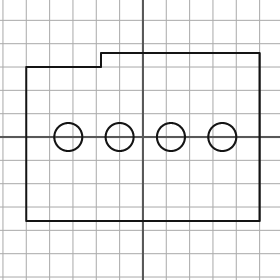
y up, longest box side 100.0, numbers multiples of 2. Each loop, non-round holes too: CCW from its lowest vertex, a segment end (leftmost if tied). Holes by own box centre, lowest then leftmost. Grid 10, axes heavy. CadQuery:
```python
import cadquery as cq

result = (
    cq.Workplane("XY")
    .moveTo(-50.0, -36.0)
    .lineTo(50.0, -36.0)
    .lineTo(50.0, 36.0)
    .lineTo(-18.0, 36.0)
    .lineTo(-18.0, 30.0)
    .lineTo(-50.0, 30.0)
    .close()
    .moveTo(-32.0, 0.0)
    .circle(6.0)
    .moveTo(-10.0, 0.0)
    .circle(6.0)
    .moveTo(12.0, 0.0)
    .circle(6.0)
    .moveTo(34.0, 0.0)
    .circle(6.0)
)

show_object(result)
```